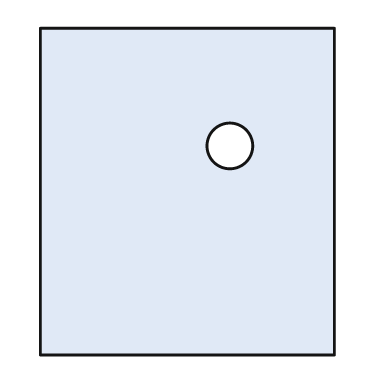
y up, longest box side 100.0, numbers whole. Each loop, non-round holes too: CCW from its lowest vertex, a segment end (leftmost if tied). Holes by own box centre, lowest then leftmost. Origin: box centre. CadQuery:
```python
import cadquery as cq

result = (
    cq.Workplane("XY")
    .moveTo(-45.0, -50.0)
    .lineTo(45.0, -50.0)
    .lineTo(45.0, 50.0)
    .lineTo(-45.0, 50.0)
    .close()
    .moveTo(13.0, 14.0)
    .circle(7.0)
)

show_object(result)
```